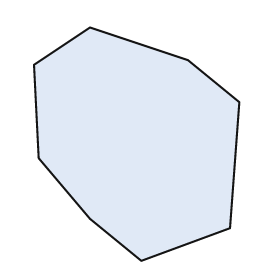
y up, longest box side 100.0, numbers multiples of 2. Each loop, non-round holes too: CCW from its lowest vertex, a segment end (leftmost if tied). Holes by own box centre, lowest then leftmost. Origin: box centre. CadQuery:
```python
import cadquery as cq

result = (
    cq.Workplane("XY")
    .moveTo(2.0, -50.0)
    .lineTo(40.0, -36.0)
    .lineTo(44.0, 18.0)
    .lineTo(22.0, 36.0)
    .lineTo(-20.0, 50.0)
    .lineTo(-44.0, 34.0)
    .lineTo(-42.0, -6.0)
    .lineTo(-20.0, -32.0)
    .close()
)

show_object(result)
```